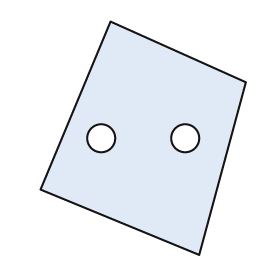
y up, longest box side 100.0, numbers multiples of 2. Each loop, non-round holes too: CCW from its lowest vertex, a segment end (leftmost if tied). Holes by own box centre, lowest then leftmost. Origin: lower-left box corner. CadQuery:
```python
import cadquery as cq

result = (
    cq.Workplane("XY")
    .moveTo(68.0, 0.0)
    .lineTo(88.0, 74.0)
    .lineTo(30.0, 100.0)
    .lineTo(0.0, 28.0)
    .close()
    .moveTo(26.0, 50.0)
    .circle(6.0)
    .moveTo(62.0, 50.0)
    .circle(6.0)
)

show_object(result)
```